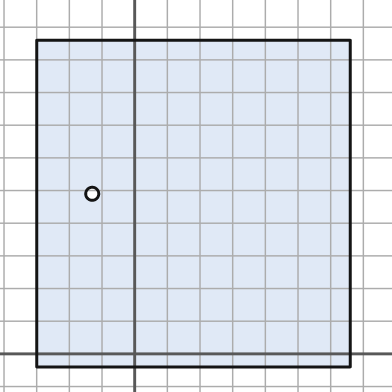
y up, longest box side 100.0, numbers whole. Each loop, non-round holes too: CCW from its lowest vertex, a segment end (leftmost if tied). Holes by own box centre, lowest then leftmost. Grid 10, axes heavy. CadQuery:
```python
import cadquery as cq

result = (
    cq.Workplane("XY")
    .moveTo(-30.0, -4.0)
    .lineTo(66.0, -4.0)
    .lineTo(66.0, 96.0)
    .lineTo(-30.0, 96.0)
    .close()
    .moveTo(-13.0, 49.0)
    .circle(2.0)
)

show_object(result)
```